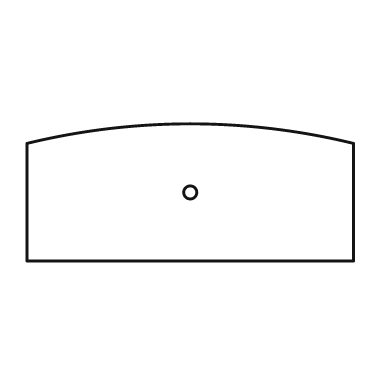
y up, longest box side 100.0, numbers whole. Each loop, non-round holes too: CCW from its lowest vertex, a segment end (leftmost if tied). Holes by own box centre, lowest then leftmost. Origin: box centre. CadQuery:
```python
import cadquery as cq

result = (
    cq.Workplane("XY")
    .moveTo(-50.0, -21.0)
    .lineTo(50.0, -21.0)
    .lineTo(50.0, 15.0)
    .threePointArc((0.0, 21.0), (-50.0, 15.0))
    .close()
    .moveTo(0.0, 0.0)
    .circle(2.0)
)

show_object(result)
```